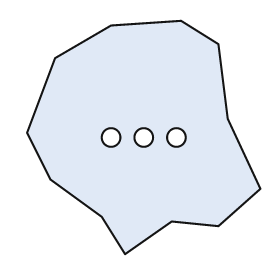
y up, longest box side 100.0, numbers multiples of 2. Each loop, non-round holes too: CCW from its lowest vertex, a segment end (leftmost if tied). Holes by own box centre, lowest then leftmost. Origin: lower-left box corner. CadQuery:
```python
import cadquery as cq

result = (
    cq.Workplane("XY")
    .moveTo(42.0, 0.0)
    .lineTo(62.0, 14.0)
    .lineTo(82.0, 12.0)
    .lineTo(100.0, 28.0)
    .lineTo(86.0, 58.0)
    .lineTo(82.0, 90.0)
    .lineTo(66.0, 100.0)
    .lineTo(36.0, 98.0)
    .lineTo(12.0, 84.0)
    .lineTo(0.0, 52.0)
    .lineTo(10.0, 32.0)
    .lineTo(32.0, 16.0)
    .close()
    .moveTo(36.0, 50.0)
    .circle(4.0)
    .moveTo(50.0, 50.0)
    .circle(4.0)
    .moveTo(64.0, 50.0)
    .circle(4.0)
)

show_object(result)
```